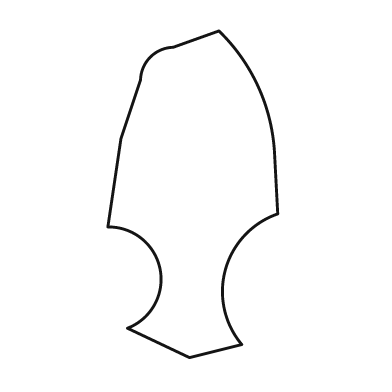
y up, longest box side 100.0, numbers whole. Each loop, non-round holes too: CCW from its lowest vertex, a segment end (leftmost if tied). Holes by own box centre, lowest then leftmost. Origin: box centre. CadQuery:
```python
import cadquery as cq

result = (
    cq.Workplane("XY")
    .moveTo(-1.0, -50.0)
    .lineTo(15.0, -46.0)
    .threePointArc((10.0, -23.0), (26.0, -6.0))
    .lineTo(25.0, 13.0)
    .threePointArc((20.0, 33.0), (8.0, 50.0))
    .lineTo(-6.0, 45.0)
    .threePointArc((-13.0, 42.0), (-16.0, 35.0))
    .lineTo(-22.0, 17.0)
    .lineTo(-26.0, -10.0)
    .threePointArc((-10.0, -23.0), (-20.0, -41.0))
    .close()
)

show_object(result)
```